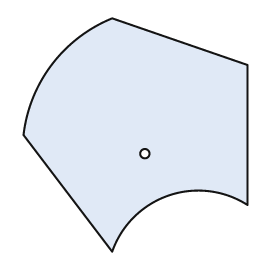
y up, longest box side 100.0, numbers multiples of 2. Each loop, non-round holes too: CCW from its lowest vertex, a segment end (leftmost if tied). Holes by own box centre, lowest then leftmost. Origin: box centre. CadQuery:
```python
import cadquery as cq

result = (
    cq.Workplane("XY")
    .moveTo(-10.0, -50.0)
    .threePointArc((14.0, -26.0), (48.0, -30.0))
    .lineTo(48.0, 30.0)
    .lineTo(-10.0, 50.0)
    .threePointArc((-36.0, 30.0), (-48.0, 0.0))
    .close()
    .moveTo(4.0, -8.0)
    .circle(2.0)
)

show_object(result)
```